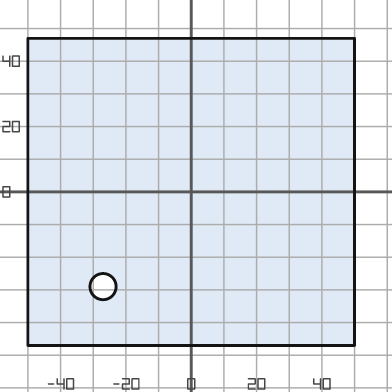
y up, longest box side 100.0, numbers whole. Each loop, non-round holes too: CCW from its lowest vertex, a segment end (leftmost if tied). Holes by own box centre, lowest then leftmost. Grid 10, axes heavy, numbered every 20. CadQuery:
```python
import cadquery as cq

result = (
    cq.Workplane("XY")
    .moveTo(-50.0, -47.0)
    .lineTo(50.0, -47.0)
    .lineTo(50.0, 47.0)
    .lineTo(-50.0, 47.0)
    .close()
    .moveTo(-27.0, -29.0)
    .circle(4.0)
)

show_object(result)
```